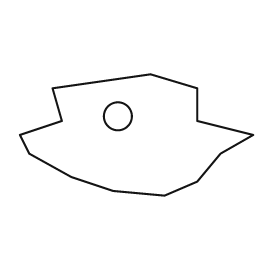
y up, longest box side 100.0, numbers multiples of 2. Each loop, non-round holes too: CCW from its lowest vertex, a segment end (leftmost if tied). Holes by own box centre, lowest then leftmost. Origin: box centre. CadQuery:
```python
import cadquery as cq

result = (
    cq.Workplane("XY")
    .moveTo(12.0, -26.0)
    .lineTo(26.0, -20.0)
    .lineTo(36.0, -8.0)
    .lineTo(50.0, 0.0)
    .lineTo(26.0, 6.0)
    .lineTo(26.0, 20.0)
    .lineTo(6.0, 26.0)
    .lineTo(-36.0, 20.0)
    .lineTo(-32.0, 6.0)
    .lineTo(-50.0, 0.0)
    .lineTo(-46.0, -8.0)
    .lineTo(-28.0, -18.0)
    .lineTo(-10.0, -24.0)
    .close()
    .moveTo(-8.0, 8.0)
    .circle(6.0)
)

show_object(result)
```